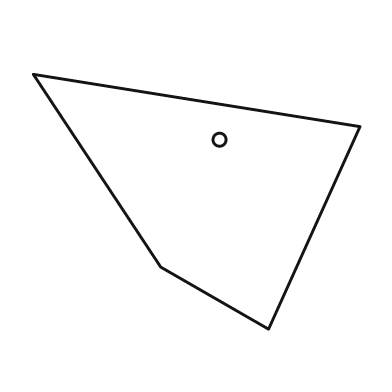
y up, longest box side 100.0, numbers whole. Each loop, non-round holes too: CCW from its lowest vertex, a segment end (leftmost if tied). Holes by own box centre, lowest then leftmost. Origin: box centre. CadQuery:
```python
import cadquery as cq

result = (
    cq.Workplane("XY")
    .moveTo(22.0, -39.0)
    .lineTo(50.0, 23.0)
    .lineTo(-50.0, 39.0)
    .lineTo(-11.0, -20.0)
    .close()
    .moveTo(7.0, 19.0)
    .circle(2.0)
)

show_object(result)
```